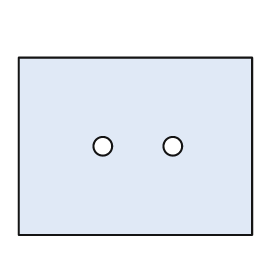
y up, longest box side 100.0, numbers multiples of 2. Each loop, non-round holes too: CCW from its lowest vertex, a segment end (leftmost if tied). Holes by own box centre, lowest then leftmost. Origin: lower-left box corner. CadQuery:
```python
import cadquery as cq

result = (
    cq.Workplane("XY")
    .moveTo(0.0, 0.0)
    .lineTo(100.0, 0.0)
    .lineTo(100.0, 76.0)
    .lineTo(0.0, 76.0)
    .close()
    .moveTo(36.0, 38.0)
    .circle(4.0)
    .moveTo(66.0, 38.0)
    .circle(4.0)
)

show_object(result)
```